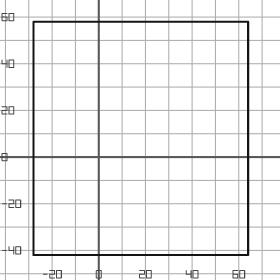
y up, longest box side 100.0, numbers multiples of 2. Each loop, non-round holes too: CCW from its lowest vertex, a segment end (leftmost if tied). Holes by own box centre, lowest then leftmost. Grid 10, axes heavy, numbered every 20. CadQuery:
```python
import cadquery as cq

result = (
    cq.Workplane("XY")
    .moveTo(-28.0, -42.0)
    .lineTo(64.0, -42.0)
    .lineTo(64.0, 58.0)
    .lineTo(-28.0, 58.0)
    .close()
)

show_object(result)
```